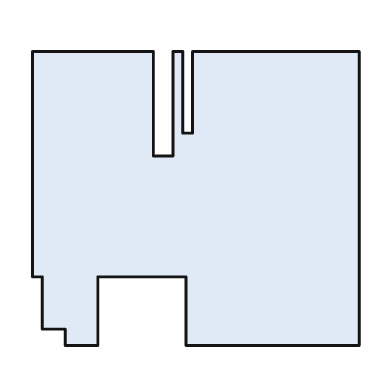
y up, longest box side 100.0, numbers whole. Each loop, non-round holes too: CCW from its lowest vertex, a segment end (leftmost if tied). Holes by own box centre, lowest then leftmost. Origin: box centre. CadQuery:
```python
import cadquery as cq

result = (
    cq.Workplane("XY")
    .moveTo(-40.0, -45.0)
    .lineTo(-30.0, -45.0)
    .lineTo(-30.0, -24.0)
    .lineTo(-3.0, -24.0)
    .lineTo(-3.0, -45.0)
    .lineTo(50.0, -45.0)
    .lineTo(50.0, 45.0)
    .lineTo(-1.0, 45.0)
    .lineTo(-1.0, 20.0)
    .lineTo(-4.0, 20.0)
    .lineTo(-4.0, 45.0)
    .lineTo(-7.0, 45.0)
    .lineTo(-7.0, 13.0)
    .lineTo(-13.0, 13.0)
    .lineTo(-13.0, 45.0)
    .lineTo(-50.0, 45.0)
    .lineTo(-50.0, -24.0)
    .lineTo(-47.0, -24.0)
    .lineTo(-47.0, -40.0)
    .lineTo(-40.0, -40.0)
    .close()
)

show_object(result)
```